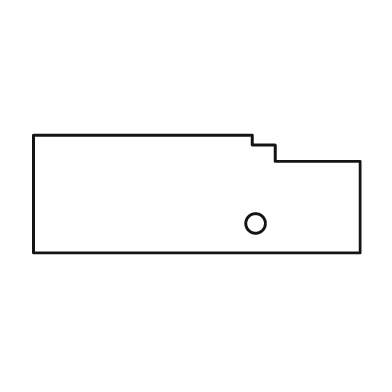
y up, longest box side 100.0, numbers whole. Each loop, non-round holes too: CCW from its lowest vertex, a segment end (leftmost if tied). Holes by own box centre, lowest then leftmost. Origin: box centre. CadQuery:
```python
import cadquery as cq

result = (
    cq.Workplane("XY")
    .moveTo(-50.0, -18.0)
    .lineTo(50.0, -18.0)
    .lineTo(50.0, 10.0)
    .lineTo(24.0, 10.0)
    .lineTo(24.0, 15.0)
    .lineTo(17.0, 15.0)
    .lineTo(17.0, 18.0)
    .lineTo(-50.0, 18.0)
    .close()
    .moveTo(18.0, -9.0)
    .circle(3.0)
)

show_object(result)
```